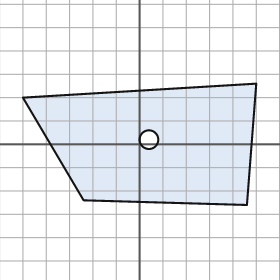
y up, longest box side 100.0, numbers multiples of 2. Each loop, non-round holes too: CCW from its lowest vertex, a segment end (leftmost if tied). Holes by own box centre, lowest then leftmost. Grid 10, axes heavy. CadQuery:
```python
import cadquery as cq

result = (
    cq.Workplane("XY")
    .moveTo(46.0, -26.0)
    .lineTo(50.0, 26.0)
    .lineTo(-50.0, 20.0)
    .lineTo(-24.0, -24.0)
    .close()
    .moveTo(4.0, 2.0)
    .circle(4.0)
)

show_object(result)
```